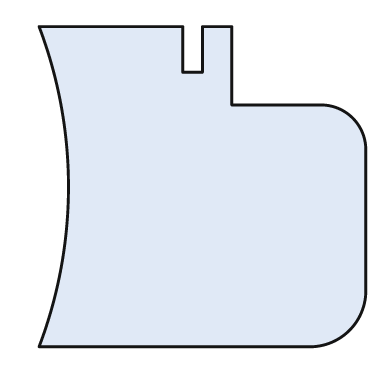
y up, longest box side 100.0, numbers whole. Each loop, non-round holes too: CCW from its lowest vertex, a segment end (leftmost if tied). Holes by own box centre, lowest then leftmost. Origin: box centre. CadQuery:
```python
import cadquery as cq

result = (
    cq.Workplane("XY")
    .moveTo(-50.0, -49.0)
    .lineTo(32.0, -49.0)
    .threePointArc((45.0, -44.0), (50.0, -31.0))
    .lineTo(50.0, 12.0)
    .threePointArc((46.0, 21.0), (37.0, 25.0))
    .lineTo(9.0, 25.0)
    .lineTo(9.0, 49.0)
    .lineTo(0.0, 49.0)
    .lineTo(0.0, 35.0)
    .lineTo(-6.0, 35.0)
    .lineTo(-6.0, 49.0)
    .lineTo(-50.0, 49.0)
    .threePointArc((-41.0, 0.0), (-50.0, -49.0))
    .close()
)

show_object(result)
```